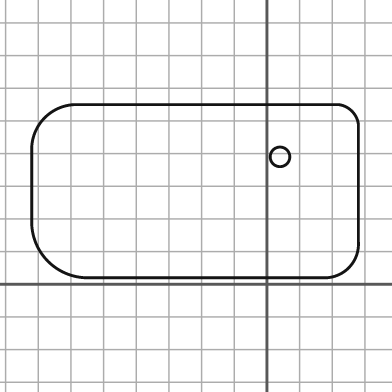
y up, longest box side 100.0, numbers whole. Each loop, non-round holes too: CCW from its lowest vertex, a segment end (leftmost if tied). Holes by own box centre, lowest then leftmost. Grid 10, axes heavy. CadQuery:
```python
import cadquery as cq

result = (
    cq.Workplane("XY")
    .moveTo(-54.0, 2.0)
    .lineTo(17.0, 2.0)
    .threePointArc((25.0, 5.0), (28.0, 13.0))
    .lineTo(28.0, 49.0)
    .threePointArc((26.0, 53.0), (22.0, 55.0))
    .lineTo(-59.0, 55.0)
    .threePointArc((-68.0, 51.0), (-72.0, 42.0))
    .lineTo(-72.0, 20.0)
    .threePointArc((-67.0, 7.0), (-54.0, 2.0))
    .close()
    .moveTo(4.0, 39.0)
    .circle(3.0)
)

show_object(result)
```